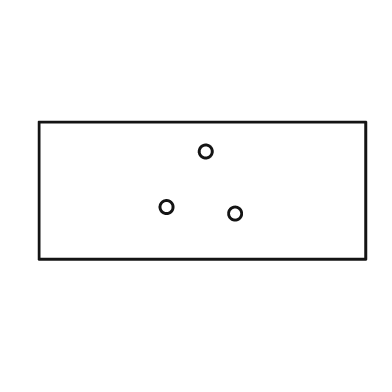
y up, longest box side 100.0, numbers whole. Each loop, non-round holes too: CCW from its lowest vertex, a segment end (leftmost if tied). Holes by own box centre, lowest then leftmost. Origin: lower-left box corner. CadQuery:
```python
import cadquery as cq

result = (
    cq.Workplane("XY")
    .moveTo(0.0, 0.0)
    .lineTo(100.0, 0.0)
    .lineTo(100.0, 42.0)
    .lineTo(0.0, 42.0)
    .close()
    .moveTo(60.0, 14.0)
    .circle(2.0)
    .moveTo(39.0, 16.0)
    .circle(2.0)
    .moveTo(51.0, 33.0)
    .circle(2.0)
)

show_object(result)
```